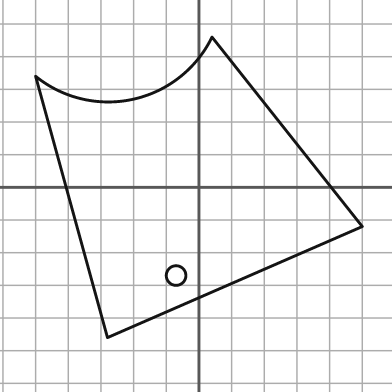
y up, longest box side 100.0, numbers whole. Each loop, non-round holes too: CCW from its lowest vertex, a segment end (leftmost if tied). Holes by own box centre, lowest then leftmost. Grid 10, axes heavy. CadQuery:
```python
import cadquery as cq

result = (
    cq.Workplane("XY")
    .moveTo(-28.0, -46.0)
    .lineTo(50.0, -12.0)
    .lineTo(4.0, 46.0)
    .threePointArc((-20.0, 27.0), (-50.0, 34.0))
    .close()
    .moveTo(-7.0, -27.0)
    .circle(3.0)
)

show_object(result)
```